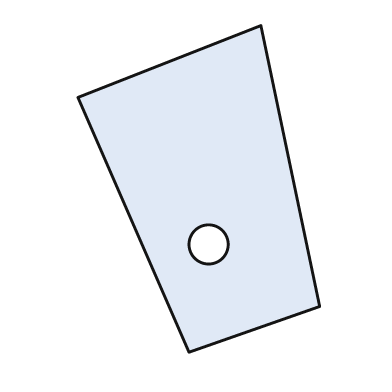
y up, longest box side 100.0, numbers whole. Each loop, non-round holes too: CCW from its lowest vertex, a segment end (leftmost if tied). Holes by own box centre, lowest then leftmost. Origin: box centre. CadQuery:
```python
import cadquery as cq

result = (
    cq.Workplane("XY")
    .moveTo(-3.0, -50.0)
    .lineTo(37.0, -36.0)
    .lineTo(19.0, 50.0)
    .lineTo(-37.0, 28.0)
    .close()
    .moveTo(3.0, -17.0)
    .circle(6.0)
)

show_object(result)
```